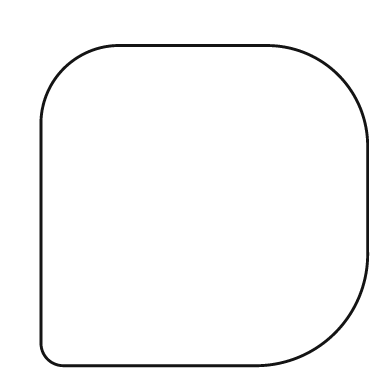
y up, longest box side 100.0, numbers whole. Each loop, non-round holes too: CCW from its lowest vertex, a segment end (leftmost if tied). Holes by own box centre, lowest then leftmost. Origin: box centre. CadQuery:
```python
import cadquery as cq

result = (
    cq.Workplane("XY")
    .moveTo(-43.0, -49.0)
    .lineTo(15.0, -49.0)
    .threePointArc((40.0, -39.0), (50.0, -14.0))
    .lineTo(50.0, 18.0)
    .threePointArc((41.0, 40.0), (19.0, 49.0))
    .lineTo(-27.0, 49.0)
    .threePointArc((-43.0, 42.0), (-50.0, 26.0))
    .lineTo(-50.0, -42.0)
    .threePointArc((-48.0, -47.0), (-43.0, -49.0))
    .close()
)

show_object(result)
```